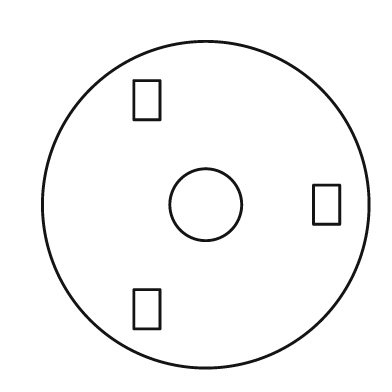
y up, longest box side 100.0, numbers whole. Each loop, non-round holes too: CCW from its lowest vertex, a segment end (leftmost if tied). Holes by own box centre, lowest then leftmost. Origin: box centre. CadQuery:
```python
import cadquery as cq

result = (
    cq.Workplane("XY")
    .moveTo(0.0, 0.0)
    .circle(50.0)
    .moveTo(-22.0, -38.0)
    .lineTo(-14.0, -38.0)
    .lineTo(-14.0, -26.0)
    .lineTo(-22.0, -26.0)
    .close()
    .moveTo(0.0, 0.0)
    .circle(11.0)
    .moveTo(33.0, -6.0)
    .lineTo(41.0, -6.0)
    .lineTo(41.0, 6.0)
    .lineTo(33.0, 6.0)
    .close()
    .moveTo(-22.0, 26.0)
    .lineTo(-14.0, 26.0)
    .lineTo(-14.0, 38.0)
    .lineTo(-22.0, 38.0)
    .close()
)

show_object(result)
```